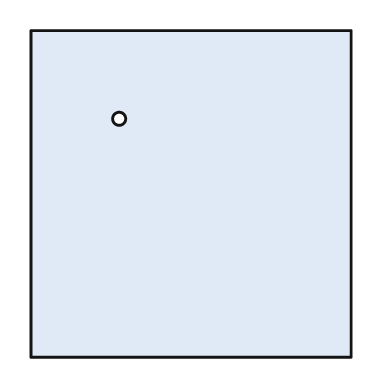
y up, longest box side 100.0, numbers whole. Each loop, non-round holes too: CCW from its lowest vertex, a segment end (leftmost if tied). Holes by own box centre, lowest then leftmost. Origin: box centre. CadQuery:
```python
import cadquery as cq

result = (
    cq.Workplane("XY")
    .moveTo(-49.0, -50.0)
    .lineTo(49.0, -50.0)
    .lineTo(49.0, 50.0)
    .lineTo(-49.0, 50.0)
    .close()
    .moveTo(-22.0, 23.0)
    .circle(2.0)
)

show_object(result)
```